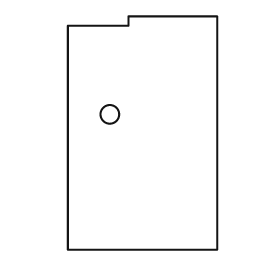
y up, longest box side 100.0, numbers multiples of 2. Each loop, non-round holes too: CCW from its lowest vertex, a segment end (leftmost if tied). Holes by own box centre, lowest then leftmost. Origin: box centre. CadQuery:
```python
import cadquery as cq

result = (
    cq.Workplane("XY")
    .moveTo(-32.0, -50.0)
    .lineTo(32.0, -50.0)
    .lineTo(32.0, 50.0)
    .lineTo(-6.0, 50.0)
    .lineTo(-6.0, 46.0)
    .lineTo(-32.0, 46.0)
    .close()
    .moveTo(-14.0, 8.0)
    .circle(4.0)
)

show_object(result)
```